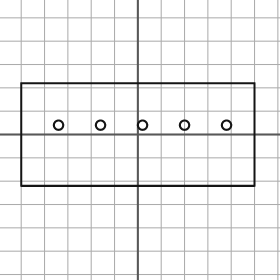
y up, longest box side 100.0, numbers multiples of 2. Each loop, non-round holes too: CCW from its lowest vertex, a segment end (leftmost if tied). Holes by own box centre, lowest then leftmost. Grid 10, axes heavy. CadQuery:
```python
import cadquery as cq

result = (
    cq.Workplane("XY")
    .moveTo(-50.0, -22.0)
    .lineTo(50.0, -22.0)
    .lineTo(50.0, 22.0)
    .lineTo(-50.0, 22.0)
    .close()
    .moveTo(-34.0, 4.0)
    .circle(2.0)
    .moveTo(-16.0, 4.0)
    .circle(2.0)
    .moveTo(2.0, 4.0)
    .circle(2.0)
    .moveTo(20.0, 4.0)
    .circle(2.0)
    .moveTo(38.0, 4.0)
    .circle(2.0)
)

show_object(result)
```